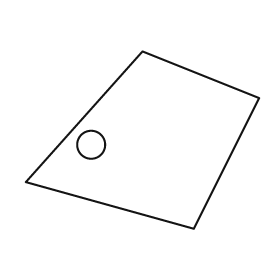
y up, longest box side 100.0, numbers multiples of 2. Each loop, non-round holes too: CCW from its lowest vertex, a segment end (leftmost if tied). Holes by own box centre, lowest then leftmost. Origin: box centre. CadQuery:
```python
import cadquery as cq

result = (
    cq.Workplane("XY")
    .moveTo(22.0, -38.0)
    .lineTo(50.0, 18.0)
    .lineTo(0.0, 38.0)
    .lineTo(-50.0, -18.0)
    .close()
    .moveTo(-22.0, -2.0)
    .circle(6.0)
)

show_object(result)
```